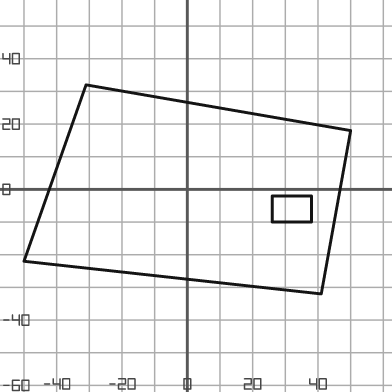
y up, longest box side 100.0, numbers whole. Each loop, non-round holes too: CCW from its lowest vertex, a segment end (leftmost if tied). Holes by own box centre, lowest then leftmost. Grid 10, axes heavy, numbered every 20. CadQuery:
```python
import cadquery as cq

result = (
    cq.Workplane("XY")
    .moveTo(41.0, -32.0)
    .lineTo(50.0, 18.0)
    .lineTo(-31.0, 32.0)
    .lineTo(-50.0, -22.0)
    .close()
    .moveTo(26.0, -10.0)
    .lineTo(38.0, -10.0)
    .lineTo(38.0, -2.0)
    .lineTo(26.0, -2.0)
    .close()
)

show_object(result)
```